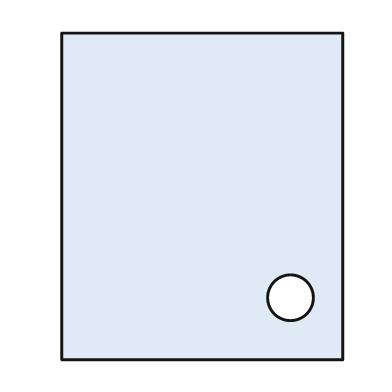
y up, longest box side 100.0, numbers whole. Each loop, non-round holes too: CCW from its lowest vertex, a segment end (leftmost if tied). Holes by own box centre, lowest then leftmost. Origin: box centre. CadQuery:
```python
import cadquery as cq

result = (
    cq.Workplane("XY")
    .moveTo(-43.0, -50.0)
    .lineTo(43.0, -50.0)
    .lineTo(43.0, 50.0)
    .lineTo(-43.0, 50.0)
    .close()
    .moveTo(27.0, -31.0)
    .circle(7.0)
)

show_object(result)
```